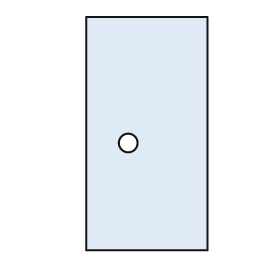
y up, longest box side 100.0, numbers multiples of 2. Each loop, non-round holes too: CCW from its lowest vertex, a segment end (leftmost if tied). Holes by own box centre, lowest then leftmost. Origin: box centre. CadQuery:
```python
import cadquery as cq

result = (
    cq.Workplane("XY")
    .moveTo(-26.0, -50.0)
    .lineTo(26.0, -50.0)
    .lineTo(26.0, 50.0)
    .lineTo(-26.0, 50.0)
    .close()
    .moveTo(-8.0, -4.0)
    .circle(4.0)
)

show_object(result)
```